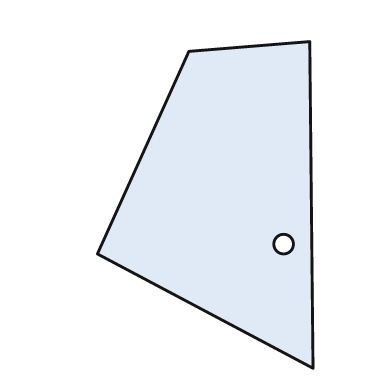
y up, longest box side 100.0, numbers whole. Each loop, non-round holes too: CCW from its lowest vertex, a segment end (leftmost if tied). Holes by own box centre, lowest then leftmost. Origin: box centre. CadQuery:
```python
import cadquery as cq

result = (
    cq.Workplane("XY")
    .moveTo(33.0, -50.0)
    .lineTo(32.0, 50.0)
    .lineTo(-5.0, 47.0)
    .lineTo(-33.0, -15.0)
    .close()
    .moveTo(24.0, -12.0)
    .circle(3.0)
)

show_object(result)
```